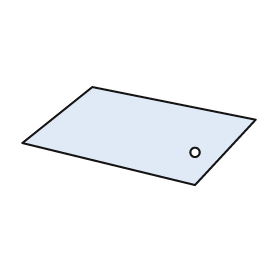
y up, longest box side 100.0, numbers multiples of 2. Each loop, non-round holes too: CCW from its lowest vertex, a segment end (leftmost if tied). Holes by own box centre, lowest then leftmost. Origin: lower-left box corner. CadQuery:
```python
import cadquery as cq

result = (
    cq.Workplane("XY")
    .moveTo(74.0, 0.0)
    .lineTo(100.0, 28.0)
    .lineTo(30.0, 42.0)
    .lineTo(0.0, 18.0)
    .close()
    .moveTo(74.0, 14.0)
    .circle(2.0)
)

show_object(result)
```